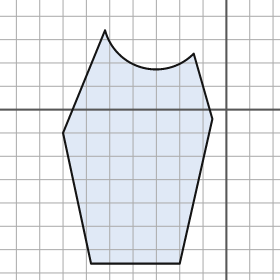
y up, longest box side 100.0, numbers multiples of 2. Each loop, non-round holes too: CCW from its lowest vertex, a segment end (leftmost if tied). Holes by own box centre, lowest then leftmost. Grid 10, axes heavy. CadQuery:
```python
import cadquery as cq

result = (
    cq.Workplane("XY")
    .moveTo(-58.0, -66.0)
    .lineTo(-20.0, -66.0)
    .lineTo(-6.0, -4.0)
    .lineTo(-14.0, 24.0)
    .threePointArc((-36.0, 18.0), (-52.0, 34.0))
    .lineTo(-70.0, -10.0)
    .close()
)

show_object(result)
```